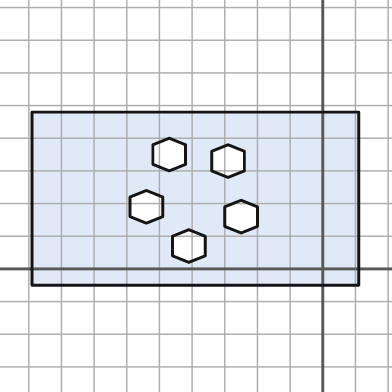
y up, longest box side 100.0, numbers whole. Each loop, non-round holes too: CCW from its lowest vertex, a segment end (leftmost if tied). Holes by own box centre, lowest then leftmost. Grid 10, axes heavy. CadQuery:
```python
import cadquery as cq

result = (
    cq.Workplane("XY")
    .moveTo(-89.0, -5.0)
    .lineTo(11.0, -5.0)
    .lineTo(11.0, 48.0)
    .lineTo(-89.0, 48.0)
    .close()
    .moveTo(-41.0, 2.0)
    .lineTo(-36.0, 4.0)
    .lineTo(-36.0, 10.0)
    .lineTo(-41.0, 12.0)
    .lineTo(-46.0, 10.0)
    .lineTo(-46.0, 4.0)
    .close()
    .moveTo(-25.0, 11.0)
    .lineTo(-20.0, 13.0)
    .lineTo(-20.0, 19.0)
    .lineTo(-25.0, 21.0)
    .lineTo(-30.0, 19.0)
    .lineTo(-30.0, 13.0)
    .close()
    .moveTo(-54.0, 14.0)
    .lineTo(-49.0, 16.0)
    .lineTo(-49.0, 22.0)
    .lineTo(-54.0, 24.0)
    .lineTo(-59.0, 22.0)
    .lineTo(-59.0, 16.0)
    .close()
    .moveTo(-29.0, 28.0)
    .lineTo(-24.0, 30.0)
    .lineTo(-24.0, 36.0)
    .lineTo(-29.0, 38.0)
    .lineTo(-34.0, 36.0)
    .lineTo(-34.0, 30.0)
    .close()
    .moveTo(-47.0, 30.0)
    .lineTo(-42.0, 32.0)
    .lineTo(-42.0, 38.0)
    .lineTo(-47.0, 40.0)
    .lineTo(-52.0, 38.0)
    .lineTo(-52.0, 32.0)
    .close()
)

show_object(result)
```